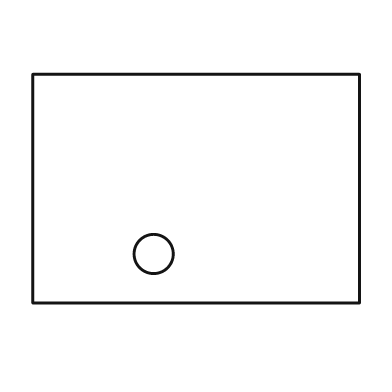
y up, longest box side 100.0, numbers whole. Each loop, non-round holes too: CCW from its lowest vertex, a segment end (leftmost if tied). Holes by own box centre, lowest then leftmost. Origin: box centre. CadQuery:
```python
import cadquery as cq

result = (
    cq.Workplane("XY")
    .moveTo(-50.0, -35.0)
    .lineTo(50.0, -35.0)
    .lineTo(50.0, 35.0)
    .lineTo(-50.0, 35.0)
    .close()
    .moveTo(-13.0, -20.0)
    .circle(6.0)
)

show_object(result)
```